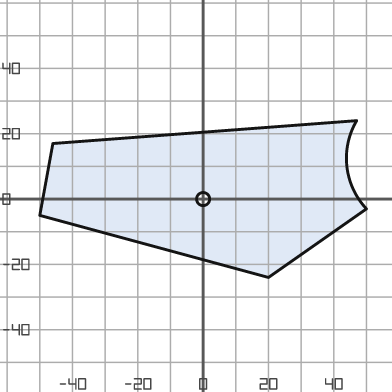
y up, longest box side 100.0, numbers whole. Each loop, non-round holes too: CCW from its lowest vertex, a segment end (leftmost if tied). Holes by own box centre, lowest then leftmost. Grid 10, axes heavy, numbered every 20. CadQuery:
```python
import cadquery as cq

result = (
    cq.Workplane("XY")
    .moveTo(20.0, -24.0)
    .lineTo(50.0, -3.0)
    .threePointArc((44.0, 10.0), (47.0, 24.0))
    .lineTo(-46.0, 17.0)
    .lineTo(-50.0, -5.0)
    .close()
    .moveTo(0.0, 0.0)
    .circle(2.0)
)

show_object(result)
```